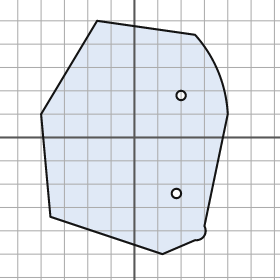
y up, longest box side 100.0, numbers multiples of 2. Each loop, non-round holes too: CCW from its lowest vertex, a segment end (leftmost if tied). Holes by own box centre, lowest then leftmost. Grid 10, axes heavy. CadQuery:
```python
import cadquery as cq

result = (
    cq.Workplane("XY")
    .moveTo(12.0, -50.0)
    .lineTo(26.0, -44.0)
    .threePointArc((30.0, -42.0), (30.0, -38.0))
    .lineTo(40.0, 10.0)
    .threePointArc((36.0, 28.0), (26.0, 44.0))
    .lineTo(-16.0, 50.0)
    .lineTo(-40.0, 10.0)
    .lineTo(-36.0, -34.0)
    .close()
    .moveTo(18.0, -24.0)
    .circle(2.0)
    .moveTo(20.0, 18.0)
    .circle(2.0)
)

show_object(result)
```